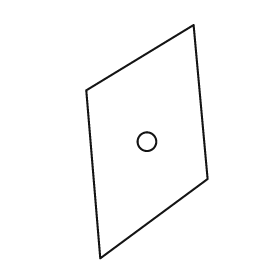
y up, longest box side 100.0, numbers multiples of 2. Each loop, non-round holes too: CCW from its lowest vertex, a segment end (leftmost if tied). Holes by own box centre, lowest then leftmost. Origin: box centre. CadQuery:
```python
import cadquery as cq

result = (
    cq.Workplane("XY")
    .moveTo(-20.0, -50.0)
    .lineTo(26.0, -16.0)
    .lineTo(20.0, 50.0)
    .lineTo(-26.0, 22.0)
    .close()
    .moveTo(0.0, 0.0)
    .circle(4.0)
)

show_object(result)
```